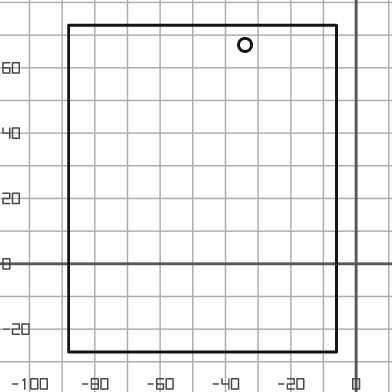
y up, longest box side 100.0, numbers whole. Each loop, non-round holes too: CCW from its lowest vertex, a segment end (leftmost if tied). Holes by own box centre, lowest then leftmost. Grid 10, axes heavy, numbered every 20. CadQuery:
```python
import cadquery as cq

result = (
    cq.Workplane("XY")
    .moveTo(-88.0, -27.0)
    .lineTo(-6.0, -27.0)
    .lineTo(-6.0, 73.0)
    .lineTo(-88.0, 73.0)
    .close()
    .moveTo(-34.0, 67.0)
    .circle(2.0)
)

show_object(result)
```